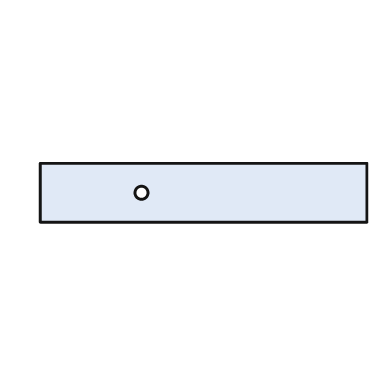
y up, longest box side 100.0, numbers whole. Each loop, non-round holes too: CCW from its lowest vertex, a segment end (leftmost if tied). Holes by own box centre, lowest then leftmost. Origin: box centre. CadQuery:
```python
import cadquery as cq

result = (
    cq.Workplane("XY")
    .moveTo(-50.0, -9.0)
    .lineTo(50.0, -9.0)
    .lineTo(50.0, 9.0)
    .lineTo(-50.0, 9.0)
    .close()
    .moveTo(-19.0, 0.0)
    .circle(2.0)
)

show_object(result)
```